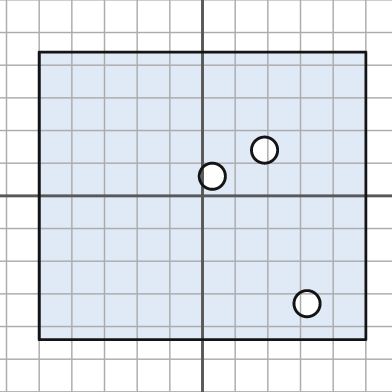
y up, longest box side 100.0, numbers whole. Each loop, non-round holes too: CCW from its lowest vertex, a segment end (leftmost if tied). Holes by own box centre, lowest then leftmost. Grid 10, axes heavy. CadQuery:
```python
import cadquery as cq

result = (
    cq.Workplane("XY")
    .moveTo(-50.0, -44.0)
    .lineTo(50.0, -44.0)
    .lineTo(50.0, 44.0)
    .lineTo(-50.0, 44.0)
    .close()
    .moveTo(32.0, -33.0)
    .circle(4.0)
    .moveTo(3.0, 6.0)
    .circle(4.0)
    .moveTo(19.0, 14.0)
    .circle(4.0)
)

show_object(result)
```